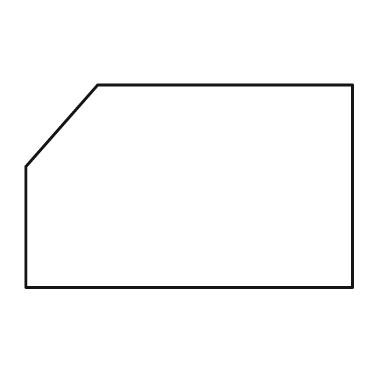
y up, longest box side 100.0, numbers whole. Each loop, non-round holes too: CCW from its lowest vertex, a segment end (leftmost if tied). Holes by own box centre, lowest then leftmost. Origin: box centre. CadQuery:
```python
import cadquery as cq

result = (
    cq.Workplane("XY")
    .moveTo(-50.0, -31.0)
    .lineTo(50.0, -31.0)
    .lineTo(50.0, 31.0)
    .lineTo(-28.0, 31.0)
    .lineTo(-50.0, 6.0)
    .close()
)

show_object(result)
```